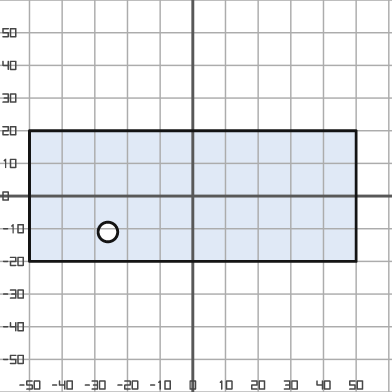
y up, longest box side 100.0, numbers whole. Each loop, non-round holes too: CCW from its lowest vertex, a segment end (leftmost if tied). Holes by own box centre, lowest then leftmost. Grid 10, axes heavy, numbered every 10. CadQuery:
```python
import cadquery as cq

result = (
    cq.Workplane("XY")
    .moveTo(-50.0, -20.0)
    .lineTo(50.0, -20.0)
    .lineTo(50.0, 20.0)
    .lineTo(-50.0, 20.0)
    .close()
    .moveTo(-26.0, -11.0)
    .circle(3.0)
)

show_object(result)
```